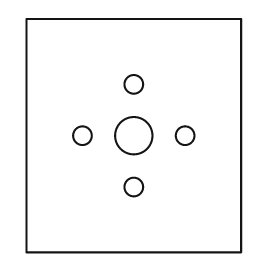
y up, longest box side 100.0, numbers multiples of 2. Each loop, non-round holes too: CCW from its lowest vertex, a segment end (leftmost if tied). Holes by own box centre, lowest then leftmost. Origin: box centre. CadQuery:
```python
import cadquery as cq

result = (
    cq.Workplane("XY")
    .moveTo(-46.0, -50.0)
    .lineTo(46.0, -50.0)
    .lineTo(46.0, 50.0)
    .lineTo(-46.0, 50.0)
    .close()
    .moveTo(0.0, -22.0)
    .circle(4.0)
    .moveTo(-22.0, 0.0)
    .circle(4.0)
    .moveTo(0.0, 0.0)
    .circle(8.0)
    .moveTo(22.0, 0.0)
    .circle(4.0)
    .moveTo(0.0, 22.0)
    .circle(4.0)
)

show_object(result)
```